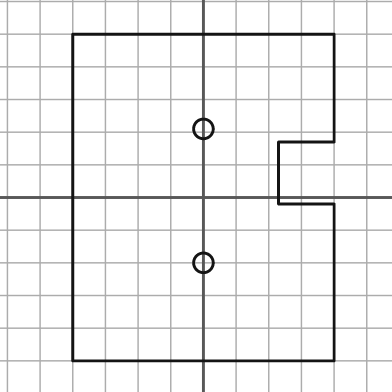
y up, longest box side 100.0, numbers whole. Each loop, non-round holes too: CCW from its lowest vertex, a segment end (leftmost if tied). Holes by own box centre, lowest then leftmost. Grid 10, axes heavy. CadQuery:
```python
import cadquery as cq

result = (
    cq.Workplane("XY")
    .moveTo(-40.0, -50.0)
    .lineTo(40.0, -50.0)
    .lineTo(40.0, -2.0)
    .lineTo(23.0, -2.0)
    .lineTo(23.0, 17.0)
    .lineTo(40.0, 17.0)
    .lineTo(40.0, 50.0)
    .lineTo(-40.0, 50.0)
    .close()
    .moveTo(0.0, -20.0)
    .circle(3.0)
    .moveTo(0.0, 21.0)
    .circle(3.0)
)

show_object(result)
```